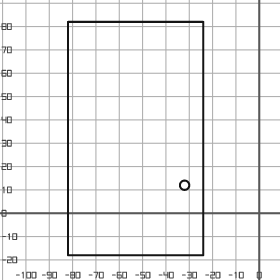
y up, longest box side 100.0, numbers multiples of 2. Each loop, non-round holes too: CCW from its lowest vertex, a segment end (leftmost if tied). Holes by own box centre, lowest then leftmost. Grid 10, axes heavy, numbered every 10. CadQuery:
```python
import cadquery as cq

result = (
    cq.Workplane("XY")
    .moveTo(-82.0, -18.0)
    .lineTo(-24.0, -18.0)
    .lineTo(-24.0, 82.0)
    .lineTo(-82.0, 82.0)
    .close()
    .moveTo(-32.0, 12.0)
    .circle(2.0)
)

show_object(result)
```